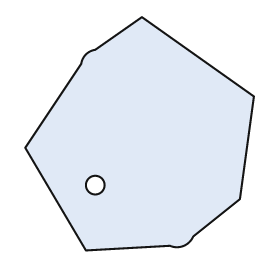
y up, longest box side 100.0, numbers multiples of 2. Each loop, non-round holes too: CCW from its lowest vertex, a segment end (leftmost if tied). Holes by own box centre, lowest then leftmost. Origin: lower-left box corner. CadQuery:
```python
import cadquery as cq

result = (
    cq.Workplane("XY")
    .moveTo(26.0, 0.0)
    .lineTo(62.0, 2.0)
    .threePointArc((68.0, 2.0), (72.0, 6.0))
    .lineTo(92.0, 22.0)
    .lineTo(98.0, 66.0)
    .lineTo(50.0, 100.0)
    .lineTo(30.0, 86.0)
    .threePointArc((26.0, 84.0), (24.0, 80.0))
    .lineTo(0.0, 44.0)
    .close()
    .moveTo(30.0, 28.0)
    .circle(4.0)
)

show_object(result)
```